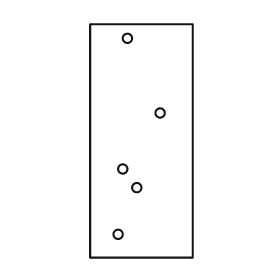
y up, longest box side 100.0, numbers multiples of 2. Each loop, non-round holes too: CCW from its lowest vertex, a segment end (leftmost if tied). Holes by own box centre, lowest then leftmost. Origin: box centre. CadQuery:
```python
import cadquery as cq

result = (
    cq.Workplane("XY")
    .moveTo(-22.0, -50.0)
    .lineTo(22.0, -50.0)
    .lineTo(22.0, 50.0)
    .lineTo(-22.0, 50.0)
    .close()
    .moveTo(-10.0, -40.0)
    .circle(2.0)
    .moveTo(-2.0, -20.0)
    .circle(2.0)
    .moveTo(-8.0, -12.0)
    .circle(2.0)
    .moveTo(8.0, 12.0)
    .circle(2.0)
    .moveTo(-6.0, 44.0)
    .circle(2.0)
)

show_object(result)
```